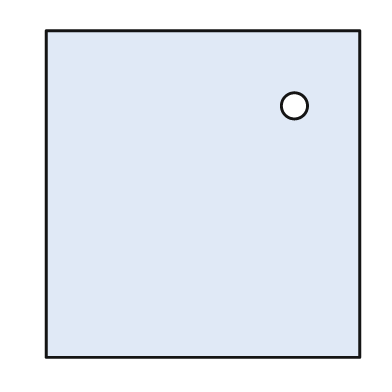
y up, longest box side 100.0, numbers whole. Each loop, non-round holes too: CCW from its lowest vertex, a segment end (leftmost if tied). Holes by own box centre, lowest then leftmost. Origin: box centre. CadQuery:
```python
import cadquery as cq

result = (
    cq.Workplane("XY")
    .moveTo(-48.0, -50.0)
    .lineTo(48.0, -50.0)
    .lineTo(48.0, 50.0)
    .lineTo(-48.0, 50.0)
    .close()
    .moveTo(28.0, 27.0)
    .circle(4.0)
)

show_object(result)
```